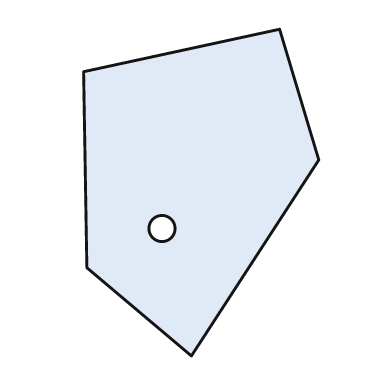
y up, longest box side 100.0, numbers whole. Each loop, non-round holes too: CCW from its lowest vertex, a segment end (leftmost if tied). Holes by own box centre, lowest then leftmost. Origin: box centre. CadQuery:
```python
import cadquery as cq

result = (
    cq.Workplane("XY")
    .moveTo(-3.0, -50.0)
    .lineTo(36.0, 10.0)
    .lineTo(24.0, 50.0)
    .lineTo(-36.0, 37.0)
    .lineTo(-35.0, -23.0)
    .close()
    .moveTo(-12.0, -11.0)
    .circle(4.0)
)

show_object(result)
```